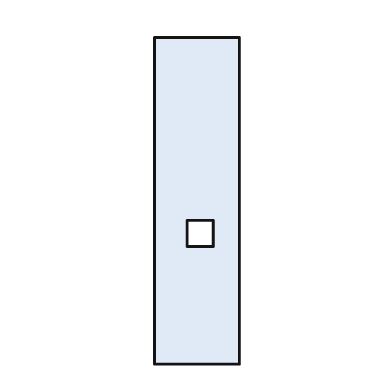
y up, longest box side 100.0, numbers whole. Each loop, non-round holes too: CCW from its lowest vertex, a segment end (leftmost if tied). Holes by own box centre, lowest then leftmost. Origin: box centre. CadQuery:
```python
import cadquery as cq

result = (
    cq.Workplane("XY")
    .moveTo(-13.0, -50.0)
    .lineTo(13.0, -50.0)
    .lineTo(13.0, 50.0)
    .lineTo(-13.0, 50.0)
    .close()
    .moveTo(-3.0, -14.0)
    .lineTo(5.0, -14.0)
    .lineTo(5.0, -6.0)
    .lineTo(-3.0, -6.0)
    .close()
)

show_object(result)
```